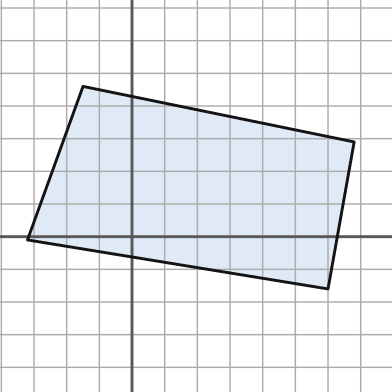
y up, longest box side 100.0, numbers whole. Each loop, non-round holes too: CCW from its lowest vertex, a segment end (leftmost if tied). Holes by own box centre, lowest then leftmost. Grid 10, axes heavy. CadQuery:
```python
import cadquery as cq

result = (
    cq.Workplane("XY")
    .moveTo(60.0, -16.0)
    .lineTo(68.0, 29.0)
    .lineTo(-15.0, 46.0)
    .lineTo(-32.0, -1.0)
    .close()
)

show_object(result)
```